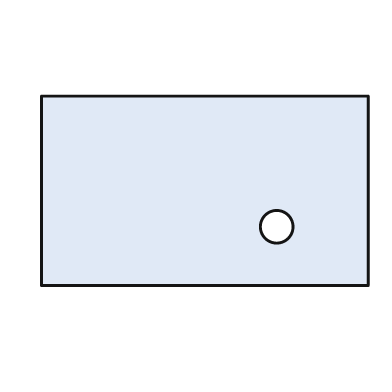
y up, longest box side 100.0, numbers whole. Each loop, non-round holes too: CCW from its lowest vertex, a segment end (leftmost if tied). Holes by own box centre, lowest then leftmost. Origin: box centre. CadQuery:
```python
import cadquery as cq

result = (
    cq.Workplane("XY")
    .moveTo(-50.0, -29.0)
    .lineTo(50.0, -29.0)
    .lineTo(50.0, 29.0)
    .lineTo(-50.0, 29.0)
    .close()
    .moveTo(22.0, -11.0)
    .circle(5.0)
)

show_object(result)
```